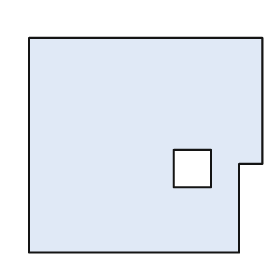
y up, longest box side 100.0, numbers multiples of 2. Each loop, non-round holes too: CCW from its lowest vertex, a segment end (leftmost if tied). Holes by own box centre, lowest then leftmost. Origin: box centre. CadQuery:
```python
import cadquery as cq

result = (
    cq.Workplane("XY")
    .moveTo(-50.0, -46.0)
    .lineTo(40.0, -46.0)
    .lineTo(40.0, -8.0)
    .lineTo(50.0, -8.0)
    .lineTo(50.0, 46.0)
    .lineTo(-50.0, 46.0)
    .close()
    .moveTo(12.0, -18.0)
    .lineTo(28.0, -18.0)
    .lineTo(28.0, -2.0)
    .lineTo(12.0, -2.0)
    .close()
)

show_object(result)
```